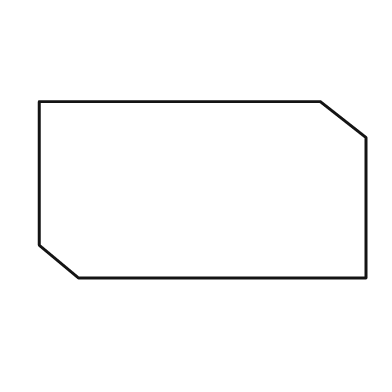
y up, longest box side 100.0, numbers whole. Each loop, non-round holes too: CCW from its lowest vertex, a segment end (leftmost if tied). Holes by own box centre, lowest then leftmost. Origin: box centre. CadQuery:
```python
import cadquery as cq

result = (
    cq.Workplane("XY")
    .moveTo(-38.0, -27.0)
    .lineTo(50.0, -27.0)
    .lineTo(50.0, 16.0)
    .lineTo(36.0, 27.0)
    .lineTo(-50.0, 27.0)
    .lineTo(-50.0, -17.0)
    .close()
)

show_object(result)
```